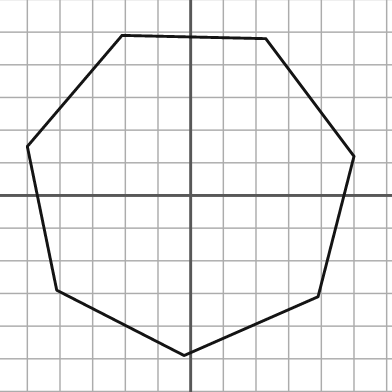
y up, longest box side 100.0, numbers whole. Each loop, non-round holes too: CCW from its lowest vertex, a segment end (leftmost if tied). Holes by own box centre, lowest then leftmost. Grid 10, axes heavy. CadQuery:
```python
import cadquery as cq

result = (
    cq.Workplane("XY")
    .moveTo(-2.0, -49.0)
    .lineTo(39.0, -31.0)
    .lineTo(50.0, 12.0)
    .lineTo(23.0, 48.0)
    .lineTo(-21.0, 49.0)
    .lineTo(-50.0, 15.0)
    .lineTo(-41.0, -29.0)
    .close()
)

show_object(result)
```